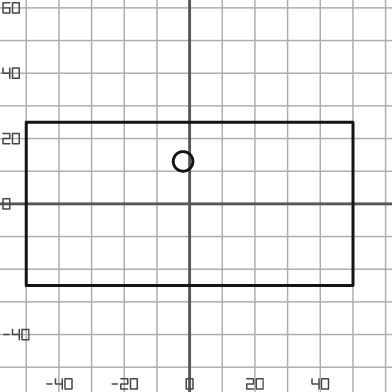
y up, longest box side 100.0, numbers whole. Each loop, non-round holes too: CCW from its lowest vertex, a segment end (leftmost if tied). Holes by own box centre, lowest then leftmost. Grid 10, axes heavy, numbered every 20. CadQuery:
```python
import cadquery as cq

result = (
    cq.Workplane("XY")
    .moveTo(-50.0, -25.0)
    .lineTo(50.0, -25.0)
    .lineTo(50.0, 25.0)
    .lineTo(-50.0, 25.0)
    .close()
    .moveTo(-2.0, 13.0)
    .circle(3.0)
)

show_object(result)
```